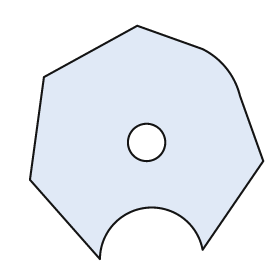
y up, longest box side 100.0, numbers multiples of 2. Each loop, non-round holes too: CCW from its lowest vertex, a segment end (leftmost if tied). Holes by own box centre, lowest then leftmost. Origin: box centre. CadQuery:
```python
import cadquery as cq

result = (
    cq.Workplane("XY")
    .moveTo(-20.0, -50.0)
    .threePointArc((0.0, -28.0), (24.0, -46.0))
    .lineTo(50.0, -8.0)
    .lineTo(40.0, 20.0)
    .threePointArc((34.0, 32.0), (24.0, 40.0))
    .lineTo(-4.0, 50.0)
    .lineTo(-44.0, 28.0)
    .lineTo(-50.0, -16.0)
    .close()
    .moveTo(0.0, 0.0)
    .circle(8.0)
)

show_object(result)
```